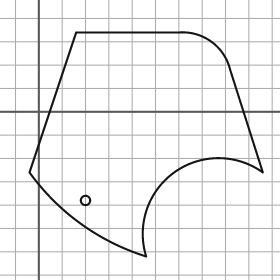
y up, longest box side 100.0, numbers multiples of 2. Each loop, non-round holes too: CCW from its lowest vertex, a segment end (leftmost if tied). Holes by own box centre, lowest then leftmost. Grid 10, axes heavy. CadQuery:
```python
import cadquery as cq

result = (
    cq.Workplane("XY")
    .moveTo(46.0, -62.0)
    .threePointArc((58.0, -26.0), (96.0, -26.0))
    .lineTo(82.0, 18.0)
    .threePointArc((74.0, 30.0), (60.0, 34.0))
    .lineTo(16.0, 34.0)
    .lineTo(-4.0, -26.0)
    .threePointArc((18.0, -48.0), (46.0, -62.0))
    .close()
    .moveTo(20.0, -38.0)
    .circle(2.0)
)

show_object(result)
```